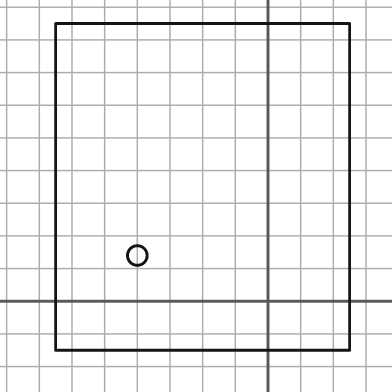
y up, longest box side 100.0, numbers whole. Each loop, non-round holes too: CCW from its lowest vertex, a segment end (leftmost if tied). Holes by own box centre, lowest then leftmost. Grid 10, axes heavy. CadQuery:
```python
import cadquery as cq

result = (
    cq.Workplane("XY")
    .moveTo(-65.0, -15.0)
    .lineTo(25.0, -15.0)
    .lineTo(25.0, 85.0)
    .lineTo(-65.0, 85.0)
    .close()
    .moveTo(-40.0, 14.0)
    .circle(3.0)
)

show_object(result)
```